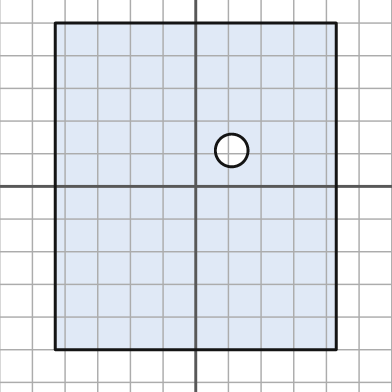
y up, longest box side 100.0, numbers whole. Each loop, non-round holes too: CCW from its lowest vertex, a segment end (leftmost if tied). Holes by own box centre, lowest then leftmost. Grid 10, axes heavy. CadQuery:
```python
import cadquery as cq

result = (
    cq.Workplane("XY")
    .moveTo(-43.0, -50.0)
    .lineTo(43.0, -50.0)
    .lineTo(43.0, 50.0)
    .lineTo(-43.0, 50.0)
    .close()
    .moveTo(11.0, 11.0)
    .circle(5.0)
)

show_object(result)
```